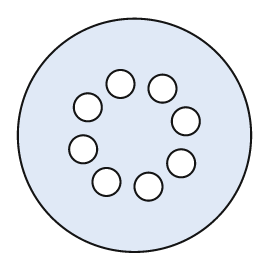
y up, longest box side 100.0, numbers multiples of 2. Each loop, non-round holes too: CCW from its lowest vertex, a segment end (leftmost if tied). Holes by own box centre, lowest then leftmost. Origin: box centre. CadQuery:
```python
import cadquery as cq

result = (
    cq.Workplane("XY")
    .moveTo(0.0, 0.0)
    .circle(50.0)
    .moveTo(6.0, -22.0)
    .circle(6.0)
    .moveTo(-12.0, -20.0)
    .circle(6.0)
    .moveTo(20.0, -12.0)
    .circle(6.0)
    .moveTo(-22.0, -6.0)
    .circle(6.0)
    .moveTo(22.0, 6.0)
    .circle(6.0)
    .moveTo(-20.0, 12.0)
    .circle(6.0)
    .moveTo(12.0, 20.0)
    .circle(6.0)
    .moveTo(-6.0, 22.0)
    .circle(6.0)
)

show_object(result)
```